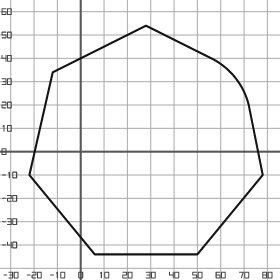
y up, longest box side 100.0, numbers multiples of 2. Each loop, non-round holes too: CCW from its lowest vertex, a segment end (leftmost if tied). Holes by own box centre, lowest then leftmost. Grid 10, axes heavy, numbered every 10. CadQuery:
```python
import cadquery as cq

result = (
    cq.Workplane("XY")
    .moveTo(6.0, -44.0)
    .lineTo(50.0, -44.0)
    .lineTo(78.0, -10.0)
    .lineTo(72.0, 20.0)
    .threePointArc((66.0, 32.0), (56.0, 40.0))
    .lineTo(28.0, 54.0)
    .lineTo(-12.0, 34.0)
    .lineTo(-22.0, -10.0)
    .close()
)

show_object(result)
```